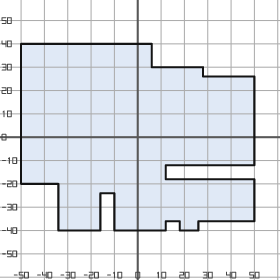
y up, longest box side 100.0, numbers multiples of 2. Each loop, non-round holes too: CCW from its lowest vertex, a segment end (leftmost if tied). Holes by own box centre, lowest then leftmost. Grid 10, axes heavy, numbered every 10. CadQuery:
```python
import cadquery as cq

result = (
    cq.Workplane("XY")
    .moveTo(-34.0, -40.0)
    .lineTo(-16.0, -40.0)
    .lineTo(-16.0, -24.0)
    .lineTo(-10.0, -24.0)
    .lineTo(-10.0, -40.0)
    .lineTo(12.0, -40.0)
    .lineTo(12.0, -36.0)
    .lineTo(18.0, -36.0)
    .lineTo(18.0, -40.0)
    .lineTo(26.0, -40.0)
    .lineTo(26.0, -36.0)
    .lineTo(50.0, -36.0)
    .lineTo(50.0, -18.0)
    .lineTo(12.0, -18.0)
    .lineTo(12.0, -12.0)
    .lineTo(50.0, -12.0)
    .lineTo(50.0, 26.0)
    .lineTo(28.0, 26.0)
    .lineTo(28.0, 30.0)
    .lineTo(6.0, 30.0)
    .lineTo(6.0, 40.0)
    .lineTo(-50.0, 40.0)
    .lineTo(-50.0, -20.0)
    .lineTo(-34.0, -20.0)
    .close()
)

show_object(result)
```